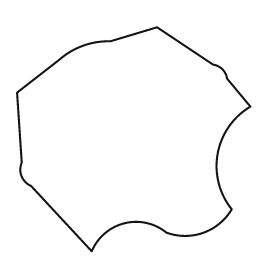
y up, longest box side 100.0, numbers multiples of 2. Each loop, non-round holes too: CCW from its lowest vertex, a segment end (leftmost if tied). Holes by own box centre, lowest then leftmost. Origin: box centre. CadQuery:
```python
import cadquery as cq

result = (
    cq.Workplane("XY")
    .moveTo(-18.0, -48.0)
    .threePointArc((-4.0, -36.0), (14.0, -40.0))
    .threePointArc((30.0, -40.0), (42.0, -30.0))
    .threePointArc((36.0, -6.0), (50.0, 14.0))
    .lineTo(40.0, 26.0)
    .threePointArc((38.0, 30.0), (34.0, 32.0))
    .lineTo(10.0, 48.0)
    .lineTo(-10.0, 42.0)
    .threePointArc((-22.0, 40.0), (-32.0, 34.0))
    .lineTo(-50.0, 20.0)
    .lineTo(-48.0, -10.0)
    .threePointArc((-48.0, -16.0), (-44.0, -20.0))
    .close()
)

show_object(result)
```